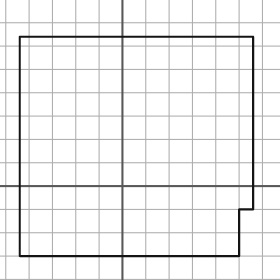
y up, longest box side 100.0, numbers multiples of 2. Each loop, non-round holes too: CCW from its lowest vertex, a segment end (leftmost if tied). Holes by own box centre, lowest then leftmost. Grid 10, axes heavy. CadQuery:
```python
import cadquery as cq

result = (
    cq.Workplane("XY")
    .moveTo(-44.0, -30.0)
    .lineTo(50.0, -30.0)
    .lineTo(50.0, -10.0)
    .lineTo(56.0, -10.0)
    .lineTo(56.0, 64.0)
    .lineTo(-44.0, 64.0)
    .close()
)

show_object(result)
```